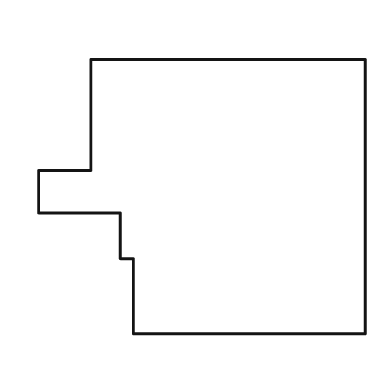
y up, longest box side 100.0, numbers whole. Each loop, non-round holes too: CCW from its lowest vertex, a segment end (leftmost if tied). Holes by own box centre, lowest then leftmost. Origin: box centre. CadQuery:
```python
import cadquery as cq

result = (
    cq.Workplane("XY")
    .moveTo(-21.0, -42.0)
    .lineTo(50.0, -42.0)
    .lineTo(50.0, 42.0)
    .lineTo(-34.0, 42.0)
    .lineTo(-34.0, 8.0)
    .lineTo(-50.0, 8.0)
    .lineTo(-50.0, -5.0)
    .lineTo(-25.0, -5.0)
    .lineTo(-25.0, -19.0)
    .lineTo(-21.0, -19.0)
    .close()
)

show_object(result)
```